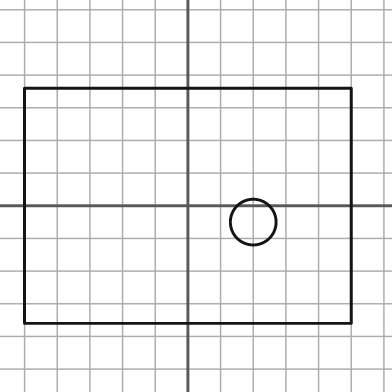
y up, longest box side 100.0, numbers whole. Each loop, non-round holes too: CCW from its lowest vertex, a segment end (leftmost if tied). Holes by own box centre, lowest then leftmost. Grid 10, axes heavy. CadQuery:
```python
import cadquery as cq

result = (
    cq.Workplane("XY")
    .moveTo(-50.0, -36.0)
    .lineTo(50.0, -36.0)
    .lineTo(50.0, 36.0)
    .lineTo(-50.0, 36.0)
    .close()
    .moveTo(20.0, -5.0)
    .circle(7.0)
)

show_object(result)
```